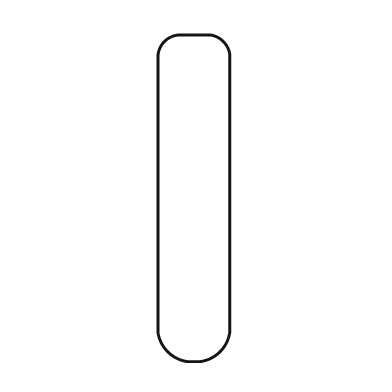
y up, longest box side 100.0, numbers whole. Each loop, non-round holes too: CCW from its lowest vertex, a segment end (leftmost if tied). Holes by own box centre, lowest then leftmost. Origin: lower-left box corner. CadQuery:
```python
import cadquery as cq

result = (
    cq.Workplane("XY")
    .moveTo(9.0, 0.0)
    .lineTo(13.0, 0.0)
    .threePointArc((19.0, 3.0), (22.0, 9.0))
    .lineTo(22.0, 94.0)
    .threePointArc((20.0, 98.0), (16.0, 100.0))
    .lineTo(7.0, 100.0)
    .threePointArc((2.0, 98.0), (0.0, 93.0))
    .lineTo(0.0, 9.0)
    .threePointArc((3.0, 3.0), (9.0, 0.0))
    .close()
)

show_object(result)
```